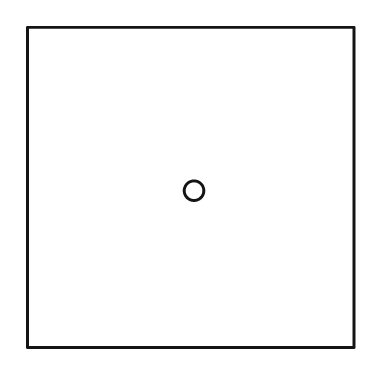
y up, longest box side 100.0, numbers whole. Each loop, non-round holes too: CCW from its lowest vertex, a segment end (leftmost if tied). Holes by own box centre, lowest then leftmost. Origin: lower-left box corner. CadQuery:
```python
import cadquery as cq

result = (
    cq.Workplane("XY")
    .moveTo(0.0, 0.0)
    .lineTo(100.0, 0.0)
    .lineTo(100.0, 98.0)
    .lineTo(0.0, 98.0)
    .close()
    .moveTo(51.0, 48.0)
    .circle(3.0)
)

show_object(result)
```